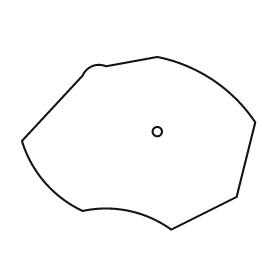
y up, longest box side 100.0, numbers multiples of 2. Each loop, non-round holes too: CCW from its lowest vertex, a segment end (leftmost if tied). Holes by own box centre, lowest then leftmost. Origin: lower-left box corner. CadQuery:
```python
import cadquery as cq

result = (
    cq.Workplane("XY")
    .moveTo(64.0, 0.0)
    .lineTo(92.0, 14.0)
    .lineTo(100.0, 46.0)
    .threePointArc((82.0, 64.0), (58.0, 74.0))
    .lineTo(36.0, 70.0)
    .threePointArc((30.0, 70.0), (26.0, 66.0))
    .lineTo(0.0, 38.0)
    .threePointArc((10.0, 20.0), (26.0, 8.0))
    .threePointArc((46.0, 8.0), (64.0, 0.0))
    .close()
    .moveTo(58.0, 42.0)
    .circle(2.0)
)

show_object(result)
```